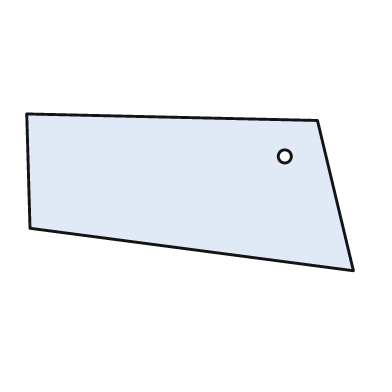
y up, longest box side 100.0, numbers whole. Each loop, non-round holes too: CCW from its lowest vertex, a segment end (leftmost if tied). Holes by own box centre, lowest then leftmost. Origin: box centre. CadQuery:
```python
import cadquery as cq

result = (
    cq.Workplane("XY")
    .moveTo(50.0, -24.0)
    .lineTo(39.0, 22.0)
    .lineTo(-50.0, 24.0)
    .lineTo(-49.0, -11.0)
    .close()
    .moveTo(29.0, 11.0)
    .circle(2.0)
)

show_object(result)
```